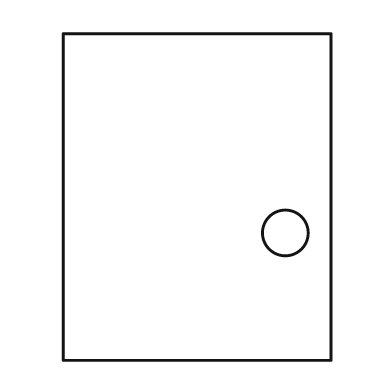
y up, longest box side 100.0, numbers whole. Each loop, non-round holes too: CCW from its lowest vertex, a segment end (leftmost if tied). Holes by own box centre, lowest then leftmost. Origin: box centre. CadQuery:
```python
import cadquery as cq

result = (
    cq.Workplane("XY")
    .moveTo(-41.0, -50.0)
    .lineTo(41.0, -50.0)
    .lineTo(41.0, 50.0)
    .lineTo(-41.0, 50.0)
    .close()
    .moveTo(27.0, -11.0)
    .circle(7.0)
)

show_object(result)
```